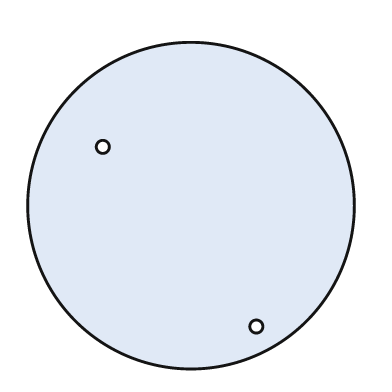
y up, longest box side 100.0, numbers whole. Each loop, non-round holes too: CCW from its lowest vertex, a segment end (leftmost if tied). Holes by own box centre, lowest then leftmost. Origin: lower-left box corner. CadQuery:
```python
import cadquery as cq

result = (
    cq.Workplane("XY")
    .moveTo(50.0, 50.0)
    .circle(50.0)
    .moveTo(70.0, 13.0)
    .circle(2.0)
    .moveTo(23.0, 68.0)
    .circle(2.0)
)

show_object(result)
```